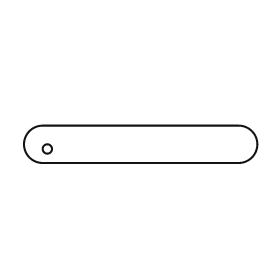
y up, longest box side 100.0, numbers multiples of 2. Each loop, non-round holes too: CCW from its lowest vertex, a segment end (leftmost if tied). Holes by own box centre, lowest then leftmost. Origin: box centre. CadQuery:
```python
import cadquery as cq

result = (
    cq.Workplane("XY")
    .moveTo(-42.0, -8.0)
    .lineTo(42.0, -8.0)
    .threePointArc((50.0, 0.0), (42.0, 8.0))
    .lineTo(-42.0, 8.0)
    .threePointArc((-50.0, 0.0), (-42.0, -8.0))
    .close()
    .moveTo(-40.0, -2.0)
    .circle(2.0)
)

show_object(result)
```